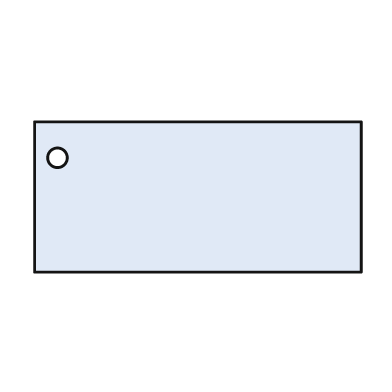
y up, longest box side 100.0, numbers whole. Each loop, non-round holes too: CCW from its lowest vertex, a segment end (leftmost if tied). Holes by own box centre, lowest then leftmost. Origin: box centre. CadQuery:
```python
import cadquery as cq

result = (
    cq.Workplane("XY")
    .moveTo(-50.0, -23.0)
    .lineTo(50.0, -23.0)
    .lineTo(50.0, 23.0)
    .lineTo(-50.0, 23.0)
    .close()
    .moveTo(-43.0, 12.0)
    .circle(3.0)
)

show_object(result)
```